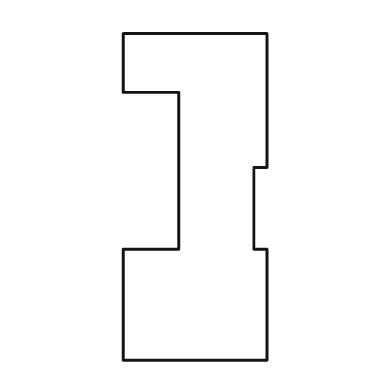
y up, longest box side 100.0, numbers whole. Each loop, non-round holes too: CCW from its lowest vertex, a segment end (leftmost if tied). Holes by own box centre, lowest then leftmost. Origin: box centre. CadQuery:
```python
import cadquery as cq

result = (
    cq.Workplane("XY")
    .moveTo(-22.0, -50.0)
    .lineTo(22.0, -50.0)
    .lineTo(22.0, -16.0)
    .lineTo(18.0, -16.0)
    .lineTo(18.0, 9.0)
    .lineTo(22.0, 9.0)
    .lineTo(22.0, 50.0)
    .lineTo(-22.0, 50.0)
    .lineTo(-22.0, 32.0)
    .lineTo(-5.0, 32.0)
    .lineTo(-5.0, -16.0)
    .lineTo(-22.0, -16.0)
    .close()
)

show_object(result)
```